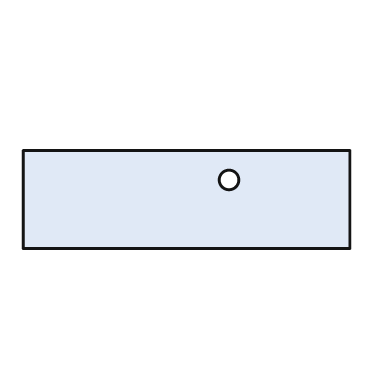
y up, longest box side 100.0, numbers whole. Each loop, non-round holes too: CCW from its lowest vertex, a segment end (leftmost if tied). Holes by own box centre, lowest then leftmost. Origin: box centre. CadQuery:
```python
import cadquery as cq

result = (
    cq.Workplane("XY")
    .moveTo(-50.0, -15.0)
    .lineTo(50.0, -15.0)
    .lineTo(50.0, 15.0)
    .lineTo(-50.0, 15.0)
    .close()
    .moveTo(13.0, 6.0)
    .circle(3.0)
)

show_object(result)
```